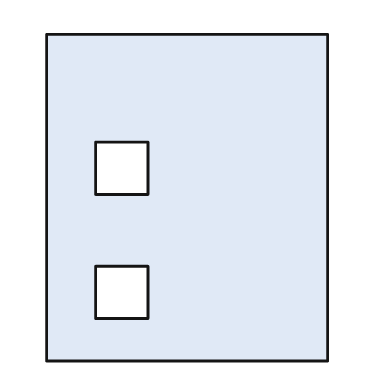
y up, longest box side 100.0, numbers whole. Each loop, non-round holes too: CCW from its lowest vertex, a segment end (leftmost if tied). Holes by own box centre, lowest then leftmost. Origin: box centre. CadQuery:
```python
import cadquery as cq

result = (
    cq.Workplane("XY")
    .moveTo(-43.0, -50.0)
    .lineTo(43.0, -50.0)
    .lineTo(43.0, 50.0)
    .lineTo(-43.0, 50.0)
    .close()
    .moveTo(-28.0, -37.0)
    .lineTo(-12.0, -37.0)
    .lineTo(-12.0, -21.0)
    .lineTo(-28.0, -21.0)
    .close()
    .moveTo(-28.0, 1.0)
    .lineTo(-12.0, 1.0)
    .lineTo(-12.0, 17.0)
    .lineTo(-28.0, 17.0)
    .close()
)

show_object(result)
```